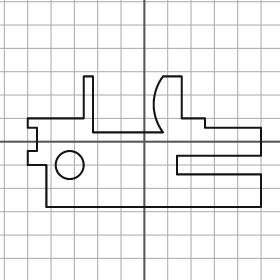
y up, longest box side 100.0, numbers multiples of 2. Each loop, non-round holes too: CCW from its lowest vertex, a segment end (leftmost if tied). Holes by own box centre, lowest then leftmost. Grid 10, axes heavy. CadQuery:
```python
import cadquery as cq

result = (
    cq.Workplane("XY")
    .moveTo(-42.0, -28.0)
    .lineTo(50.0, -28.0)
    .lineTo(50.0, -14.0)
    .lineTo(14.0, -14.0)
    .lineTo(14.0, -6.0)
    .lineTo(50.0, -6.0)
    .lineTo(50.0, 6.0)
    .lineTo(26.0, 6.0)
    .lineTo(26.0, 10.0)
    .lineTo(16.0, 10.0)
    .lineTo(16.0, 28.0)
    .lineTo(8.0, 28.0)
    .threePointArc((4.0, 16.0), (8.0, 4.0))
    .lineTo(-22.0, 4.0)
    .lineTo(-22.0, 28.0)
    .lineTo(-26.0, 28.0)
    .lineTo(-26.0, 10.0)
    .lineTo(-50.0, 10.0)
    .lineTo(-50.0, 6.0)
    .lineTo(-46.0, 6.0)
    .lineTo(-46.0, -4.0)
    .lineTo(-50.0, -4.0)
    .lineTo(-50.0, -10.0)
    .lineTo(-42.0, -10.0)
    .close()
    .moveTo(-32.0, -10.0)
    .circle(6.0)
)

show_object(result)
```